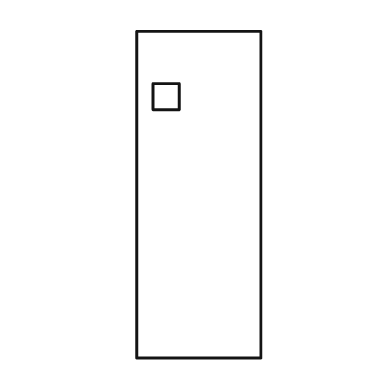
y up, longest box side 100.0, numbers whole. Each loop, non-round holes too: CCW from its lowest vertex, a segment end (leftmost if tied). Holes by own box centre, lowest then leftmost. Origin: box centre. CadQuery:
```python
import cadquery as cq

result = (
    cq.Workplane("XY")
    .moveTo(-19.0, -50.0)
    .lineTo(19.0, -50.0)
    .lineTo(19.0, 50.0)
    .lineTo(-19.0, 50.0)
    .close()
    .moveTo(-14.0, 26.0)
    .lineTo(-6.0, 26.0)
    .lineTo(-6.0, 34.0)
    .lineTo(-14.0, 34.0)
    .close()
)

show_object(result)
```